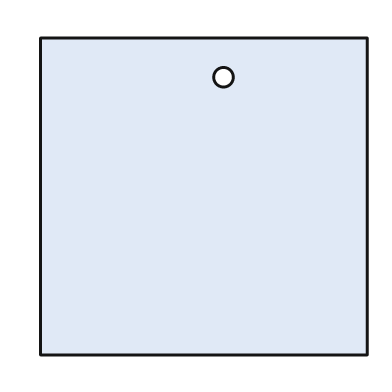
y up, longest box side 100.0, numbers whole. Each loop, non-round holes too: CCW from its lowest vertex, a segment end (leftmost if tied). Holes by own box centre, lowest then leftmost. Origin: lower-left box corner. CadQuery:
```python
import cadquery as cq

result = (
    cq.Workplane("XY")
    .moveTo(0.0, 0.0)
    .lineTo(100.0, 0.0)
    .lineTo(100.0, 97.0)
    .lineTo(0.0, 97.0)
    .close()
    .moveTo(56.0, 85.0)
    .circle(3.0)
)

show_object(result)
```